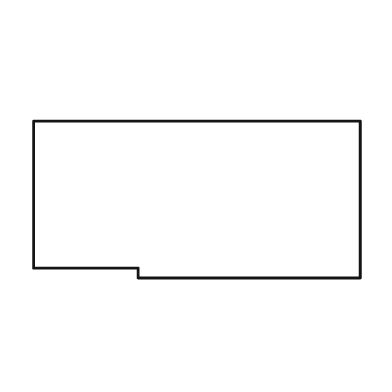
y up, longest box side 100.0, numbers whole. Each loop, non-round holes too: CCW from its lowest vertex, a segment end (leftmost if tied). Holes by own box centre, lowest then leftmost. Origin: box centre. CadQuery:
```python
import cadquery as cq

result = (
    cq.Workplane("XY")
    .moveTo(-18.0, -24.0)
    .lineTo(50.0, -24.0)
    .lineTo(50.0, 24.0)
    .lineTo(-50.0, 24.0)
    .lineTo(-50.0, -21.0)
    .lineTo(-18.0, -21.0)
    .close()
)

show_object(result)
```